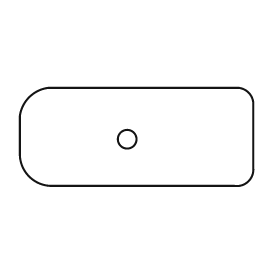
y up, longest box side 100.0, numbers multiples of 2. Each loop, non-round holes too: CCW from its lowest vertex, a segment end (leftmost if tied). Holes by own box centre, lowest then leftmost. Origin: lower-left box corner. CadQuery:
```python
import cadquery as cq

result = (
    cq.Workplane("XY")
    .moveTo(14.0, 0.0)
    .lineTo(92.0, 0.0)
    .threePointArc((98.0, 2.0), (100.0, 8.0))
    .lineTo(100.0, 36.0)
    .threePointArc((98.0, 40.0), (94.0, 42.0))
    .lineTo(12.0, 42.0)
    .threePointArc((4.0, 38.0), (0.0, 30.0))
    .lineTo(0.0, 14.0)
    .threePointArc((4.0, 4.0), (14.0, 0.0))
    .close()
    .moveTo(46.0, 20.0)
    .circle(4.0)
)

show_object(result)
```